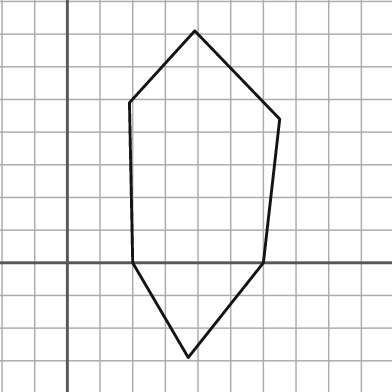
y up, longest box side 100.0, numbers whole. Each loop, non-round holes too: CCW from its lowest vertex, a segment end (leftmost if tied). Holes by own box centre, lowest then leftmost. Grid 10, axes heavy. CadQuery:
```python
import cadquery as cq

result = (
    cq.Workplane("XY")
    .moveTo(37.0, -29.0)
    .lineTo(60.0, 0.0)
    .lineTo(65.0, 44.0)
    .lineTo(39.0, 71.0)
    .lineTo(19.0, 49.0)
    .lineTo(20.0, 0.0)
    .close()
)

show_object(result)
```